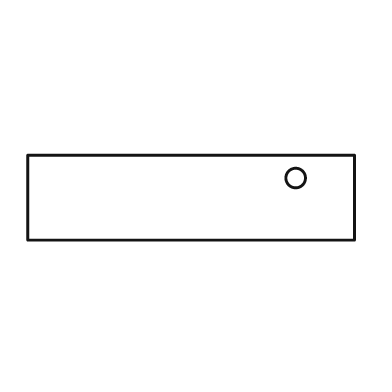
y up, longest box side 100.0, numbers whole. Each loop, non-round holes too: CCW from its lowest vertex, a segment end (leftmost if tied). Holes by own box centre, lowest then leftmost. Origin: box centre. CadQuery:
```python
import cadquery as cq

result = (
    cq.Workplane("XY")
    .moveTo(-50.0, -13.0)
    .lineTo(50.0, -13.0)
    .lineTo(50.0, 13.0)
    .lineTo(-50.0, 13.0)
    .close()
    .moveTo(32.0, 6.0)
    .circle(3.0)
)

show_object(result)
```